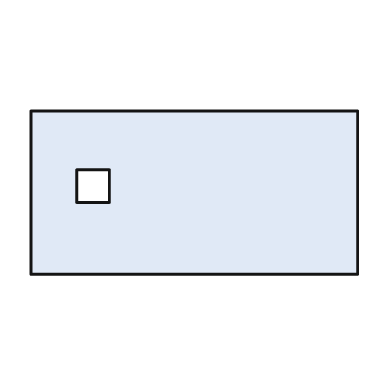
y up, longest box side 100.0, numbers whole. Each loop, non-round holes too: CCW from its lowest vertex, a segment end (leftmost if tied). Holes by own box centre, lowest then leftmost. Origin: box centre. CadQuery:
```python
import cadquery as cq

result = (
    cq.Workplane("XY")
    .moveTo(-50.0, -25.0)
    .lineTo(50.0, -25.0)
    .lineTo(50.0, 25.0)
    .lineTo(-50.0, 25.0)
    .close()
    .moveTo(-36.0, -3.0)
    .lineTo(-26.0, -3.0)
    .lineTo(-26.0, 7.0)
    .lineTo(-36.0, 7.0)
    .close()
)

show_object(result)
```